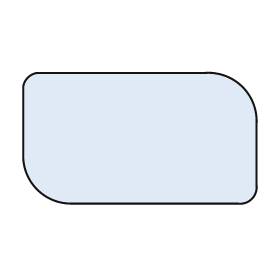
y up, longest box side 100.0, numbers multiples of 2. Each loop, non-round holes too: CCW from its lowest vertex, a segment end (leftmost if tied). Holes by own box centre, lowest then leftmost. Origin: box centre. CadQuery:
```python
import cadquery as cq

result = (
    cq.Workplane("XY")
    .moveTo(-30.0, -28.0)
    .lineTo(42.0, -28.0)
    .threePointArc((48.0, -26.0), (50.0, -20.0))
    .lineTo(50.0, 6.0)
    .threePointArc((44.0, 22.0), (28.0, 28.0))
    .lineTo(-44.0, 28.0)
    .threePointArc((-48.0, 26.0), (-50.0, 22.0))
    .lineTo(-50.0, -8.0)
    .threePointArc((-44.0, -22.0), (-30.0, -28.0))
    .close()
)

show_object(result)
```